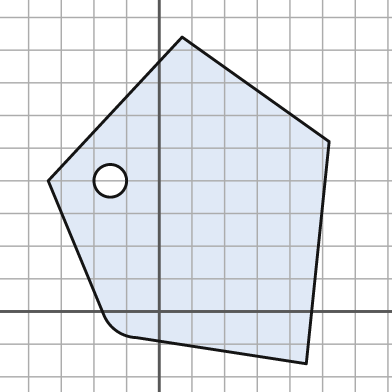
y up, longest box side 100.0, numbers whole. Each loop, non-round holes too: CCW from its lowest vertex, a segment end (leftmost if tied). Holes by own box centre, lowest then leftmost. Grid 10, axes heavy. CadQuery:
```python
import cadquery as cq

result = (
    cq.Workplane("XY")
    .moveTo(45.0, -16.0)
    .lineTo(52.0, 52.0)
    .lineTo(7.0, 84.0)
    .lineTo(-34.0, 40.0)
    .lineTo(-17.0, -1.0)
    .threePointArc((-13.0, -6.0), (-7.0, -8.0))
    .close()
    .moveTo(-15.0, 40.0)
    .circle(5.0)
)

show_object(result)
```